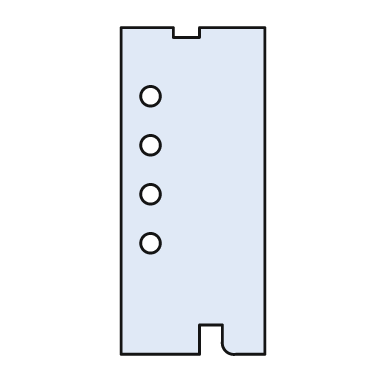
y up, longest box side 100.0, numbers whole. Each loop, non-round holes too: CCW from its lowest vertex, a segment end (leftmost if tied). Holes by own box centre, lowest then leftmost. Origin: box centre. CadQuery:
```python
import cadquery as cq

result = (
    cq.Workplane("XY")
    .moveTo(-22.0, -50.0)
    .lineTo(2.0, -50.0)
    .lineTo(2.0, -41.0)
    .lineTo(9.0, -41.0)
    .lineTo(9.0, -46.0)
    .threePointArc((10.0, -49.0), (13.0, -50.0))
    .lineTo(22.0, -50.0)
    .lineTo(22.0, 50.0)
    .lineTo(2.0, 50.0)
    .lineTo(2.0, 47.0)
    .lineTo(-6.0, 47.0)
    .lineTo(-6.0, 50.0)
    .lineTo(-22.0, 50.0)
    .close()
    .moveTo(-13.0, -16.0)
    .circle(3.0)
    .moveTo(-13.0, -1.0)
    .circle(3.0)
    .moveTo(-13.0, 14.0)
    .circle(3.0)
    .moveTo(-13.0, 29.0)
    .circle(3.0)
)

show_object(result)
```